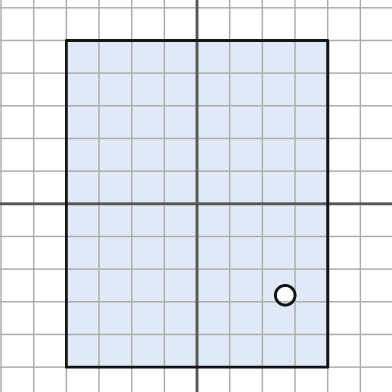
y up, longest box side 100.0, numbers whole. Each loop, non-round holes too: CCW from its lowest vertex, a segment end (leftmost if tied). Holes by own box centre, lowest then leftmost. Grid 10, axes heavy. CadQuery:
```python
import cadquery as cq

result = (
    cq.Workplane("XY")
    .moveTo(-40.0, -50.0)
    .lineTo(40.0, -50.0)
    .lineTo(40.0, 50.0)
    .lineTo(-40.0, 50.0)
    .close()
    .moveTo(27.0, -28.0)
    .circle(3.0)
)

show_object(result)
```